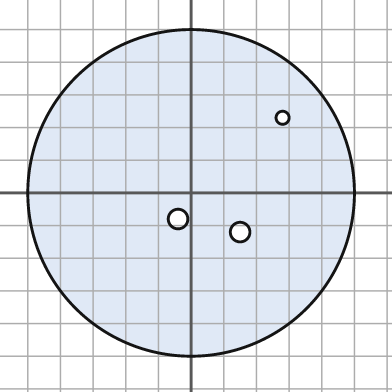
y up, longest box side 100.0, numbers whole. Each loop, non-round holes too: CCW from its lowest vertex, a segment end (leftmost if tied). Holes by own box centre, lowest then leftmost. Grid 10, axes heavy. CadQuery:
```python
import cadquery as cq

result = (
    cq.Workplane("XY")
    .moveTo(0.0, 0.0)
    .circle(50.0)
    .moveTo(15.0, -12.0)
    .circle(3.0)
    .moveTo(-4.0, -8.0)
    .circle(3.0)
    .moveTo(28.0, 23.0)
    .circle(2.0)
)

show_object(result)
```